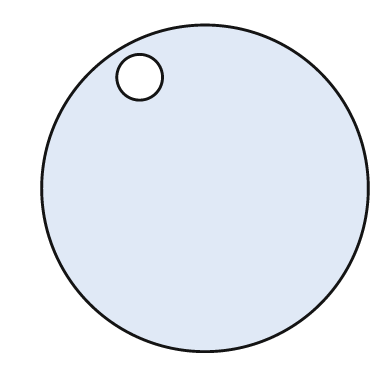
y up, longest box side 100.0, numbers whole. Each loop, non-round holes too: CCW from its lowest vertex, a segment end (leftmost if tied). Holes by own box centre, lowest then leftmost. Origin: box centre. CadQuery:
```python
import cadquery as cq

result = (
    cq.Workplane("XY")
    .moveTo(0.0, 0.0)
    .circle(50.0)
    .moveTo(-20.0, 34.0)
    .circle(7.0)
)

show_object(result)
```